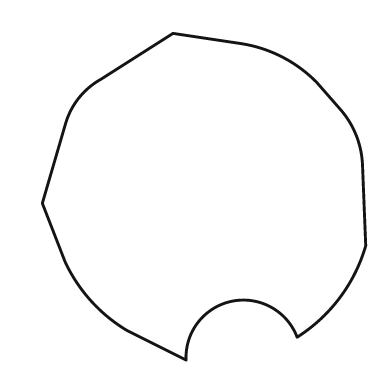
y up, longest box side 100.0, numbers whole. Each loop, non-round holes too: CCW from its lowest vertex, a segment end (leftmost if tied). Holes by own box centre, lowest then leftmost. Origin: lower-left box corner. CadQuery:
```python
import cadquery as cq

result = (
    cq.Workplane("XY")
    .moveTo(44.0, 0.0)
    .threePointArc((58.0, 18.0), (78.0, 7.0))
    .threePointArc((91.0, 19.0), (99.0, 35.0))
    .lineTo(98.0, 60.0)
    .threePointArc((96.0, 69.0), (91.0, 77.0))
    .lineTo(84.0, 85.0)
    .threePointArc((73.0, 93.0), (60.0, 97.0))
    .lineTo(40.0, 100.0)
    .lineTo(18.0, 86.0)
    .threePointArc((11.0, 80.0), (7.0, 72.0))
    .lineTo(0.0, 48.0)
    .lineTo(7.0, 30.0)
    .threePointArc((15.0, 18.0), (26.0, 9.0))
    .close()
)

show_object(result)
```